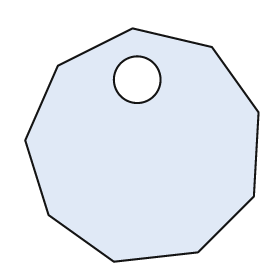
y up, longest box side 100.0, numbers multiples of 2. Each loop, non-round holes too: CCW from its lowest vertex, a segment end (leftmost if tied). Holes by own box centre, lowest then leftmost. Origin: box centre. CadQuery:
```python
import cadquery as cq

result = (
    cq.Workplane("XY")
    .moveTo(-12.0, -50.0)
    .lineTo(24.0, -46.0)
    .lineTo(48.0, -22.0)
    .lineTo(50.0, 14.0)
    .lineTo(30.0, 42.0)
    .lineTo(-4.0, 50.0)
    .lineTo(-36.0, 34.0)
    .lineTo(-50.0, 2.0)
    .lineTo(-40.0, -30.0)
    .close()
    .moveTo(-2.0, 28.0)
    .circle(10.0)
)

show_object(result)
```